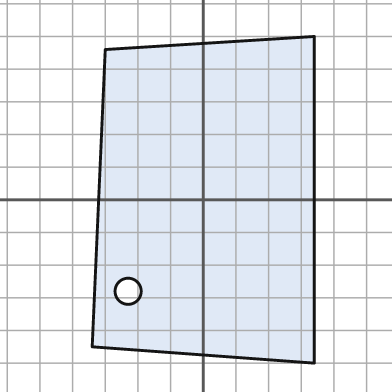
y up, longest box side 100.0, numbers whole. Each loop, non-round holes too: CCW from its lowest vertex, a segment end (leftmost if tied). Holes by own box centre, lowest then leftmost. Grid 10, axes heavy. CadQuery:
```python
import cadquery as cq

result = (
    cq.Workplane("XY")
    .moveTo(34.0, -50.0)
    .lineTo(34.0, 50.0)
    .lineTo(-30.0, 46.0)
    .lineTo(-34.0, -45.0)
    .close()
    .moveTo(-23.0, -28.0)
    .circle(4.0)
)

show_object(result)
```